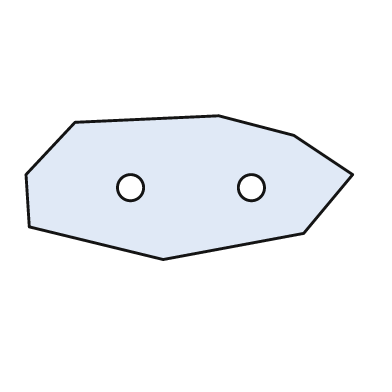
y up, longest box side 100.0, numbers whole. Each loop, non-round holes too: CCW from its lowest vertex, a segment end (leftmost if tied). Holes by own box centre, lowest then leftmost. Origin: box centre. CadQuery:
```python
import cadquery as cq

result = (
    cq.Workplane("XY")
    .moveTo(-8.0, -22.0)
    .lineTo(35.0, -14.0)
    .lineTo(50.0, 4.0)
    .lineTo(32.0, 16.0)
    .lineTo(9.0, 22.0)
    .lineTo(-35.0, 20.0)
    .lineTo(-50.0, 4.0)
    .lineTo(-49.0, -12.0)
    .close()
    .moveTo(-18.0, 0.0)
    .circle(4.0)
    .moveTo(19.0, 0.0)
    .circle(4.0)
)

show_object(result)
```